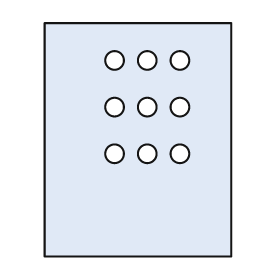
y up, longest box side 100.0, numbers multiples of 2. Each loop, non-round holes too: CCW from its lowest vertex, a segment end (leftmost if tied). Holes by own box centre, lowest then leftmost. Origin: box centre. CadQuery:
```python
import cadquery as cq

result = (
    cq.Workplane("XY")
    .moveTo(-40.0, -50.0)
    .lineTo(40.0, -50.0)
    .lineTo(40.0, 50.0)
    .lineTo(-40.0, 50.0)
    .close()
    .moveTo(-10.0, -6.0)
    .circle(4.0)
    .moveTo(4.0, -6.0)
    .circle(4.0)
    .moveTo(18.0, -6.0)
    .circle(4.0)
    .moveTo(-10.0, 14.0)
    .circle(4.0)
    .moveTo(4.0, 14.0)
    .circle(4.0)
    .moveTo(18.0, 14.0)
    .circle(4.0)
    .moveTo(-10.0, 34.0)
    .circle(4.0)
    .moveTo(4.0, 34.0)
    .circle(4.0)
    .moveTo(18.0, 34.0)
    .circle(4.0)
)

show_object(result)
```